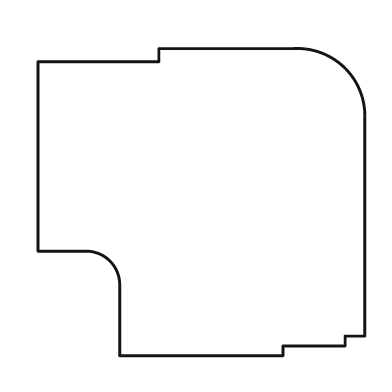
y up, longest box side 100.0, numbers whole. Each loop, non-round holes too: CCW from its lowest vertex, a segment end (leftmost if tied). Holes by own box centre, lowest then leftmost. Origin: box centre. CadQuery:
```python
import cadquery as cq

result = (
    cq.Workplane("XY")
    .moveTo(-25.0, -47.0)
    .lineTo(25.0, -47.0)
    .lineTo(25.0, -44.0)
    .lineTo(44.0, -44.0)
    .lineTo(44.0, -41.0)
    .lineTo(50.0, -41.0)
    .lineTo(50.0, 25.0)
    .threePointArc((44.0, 41.0), (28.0, 47.0))
    .lineTo(-13.0, 47.0)
    .lineTo(-13.0, 43.0)
    .lineTo(-50.0, 43.0)
    .lineTo(-50.0, -15.0)
    .lineTo(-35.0, -15.0)
    .threePointArc((-28.0, -18.0), (-25.0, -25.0))
    .close()
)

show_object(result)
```